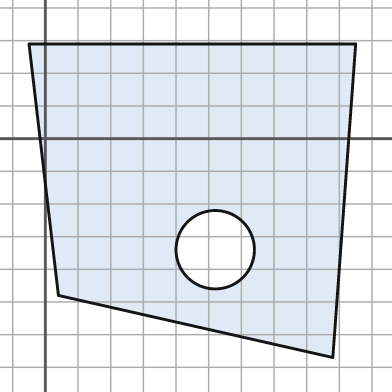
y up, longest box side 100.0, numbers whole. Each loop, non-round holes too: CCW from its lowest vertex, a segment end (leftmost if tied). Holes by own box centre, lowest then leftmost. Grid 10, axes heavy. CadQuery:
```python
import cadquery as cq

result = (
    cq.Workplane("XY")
    .moveTo(88.0, -67.0)
    .lineTo(95.0, 29.0)
    .lineTo(-5.0, 29.0)
    .lineTo(4.0, -48.0)
    .close()
    .moveTo(52.0, -34.0)
    .circle(12.0)
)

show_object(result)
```